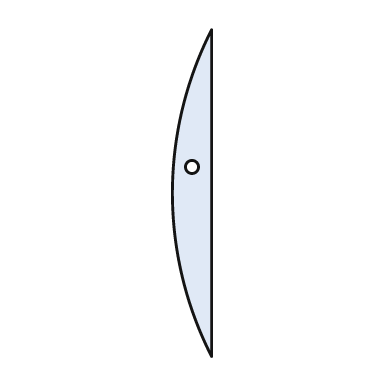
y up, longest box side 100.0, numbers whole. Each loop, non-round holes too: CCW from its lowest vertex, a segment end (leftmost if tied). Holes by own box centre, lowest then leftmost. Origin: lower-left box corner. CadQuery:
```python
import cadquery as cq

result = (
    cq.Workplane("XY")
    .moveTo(12.0, 0.0)
    .lineTo(12.0, 100.0)
    .threePointArc((0.0, 50.0), (12.0, 0.0))
    .close()
    .moveTo(6.0, 58.0)
    .circle(2.0)
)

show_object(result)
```